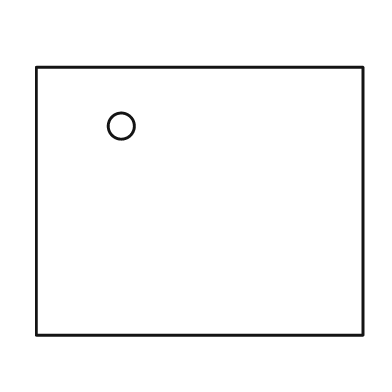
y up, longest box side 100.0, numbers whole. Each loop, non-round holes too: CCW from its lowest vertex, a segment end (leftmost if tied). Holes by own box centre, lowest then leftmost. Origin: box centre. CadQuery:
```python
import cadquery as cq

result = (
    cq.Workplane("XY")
    .moveTo(-50.0, -41.0)
    .lineTo(50.0, -41.0)
    .lineTo(50.0, 41.0)
    .lineTo(-50.0, 41.0)
    .close()
    .moveTo(-24.0, 23.0)
    .circle(4.0)
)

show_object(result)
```